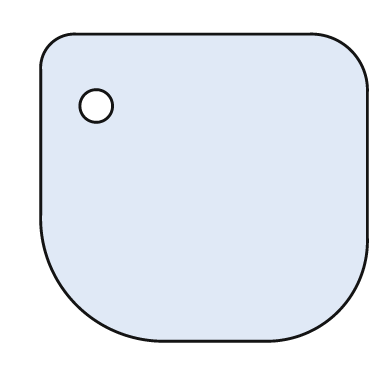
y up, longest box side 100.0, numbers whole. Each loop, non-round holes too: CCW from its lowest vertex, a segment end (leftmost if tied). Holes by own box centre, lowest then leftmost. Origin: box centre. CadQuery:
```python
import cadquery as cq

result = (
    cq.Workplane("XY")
    .moveTo(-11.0, -47.0)
    .lineTo(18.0, -47.0)
    .threePointArc((41.0, -38.0), (50.0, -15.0))
    .lineTo(50.0, 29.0)
    .threePointArc((45.0, 42.0), (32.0, 47.0))
    .lineTo(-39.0, 47.0)
    .threePointArc((-47.0, 44.0), (-50.0, 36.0))
    .lineTo(-50.0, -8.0)
    .threePointArc((-39.0, -36.0), (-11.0, -47.0))
    .close()
    .moveTo(-33.0, 25.0)
    .circle(5.0)
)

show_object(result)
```